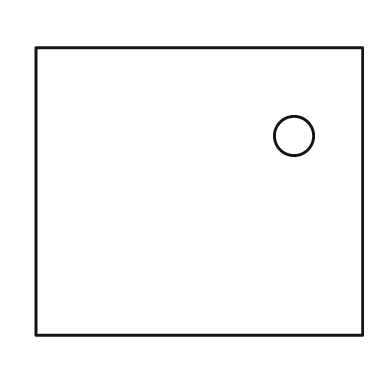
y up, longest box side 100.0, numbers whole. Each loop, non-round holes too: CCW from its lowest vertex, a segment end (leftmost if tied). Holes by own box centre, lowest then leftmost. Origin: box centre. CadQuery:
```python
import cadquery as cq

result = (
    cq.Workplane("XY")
    .moveTo(-50.0, -44.0)
    .lineTo(50.0, -44.0)
    .lineTo(50.0, 44.0)
    .lineTo(-50.0, 44.0)
    .close()
    .moveTo(29.0, 17.0)
    .circle(6.0)
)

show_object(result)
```